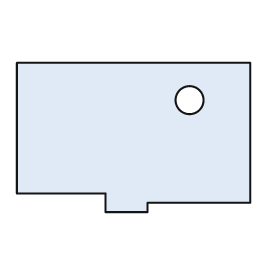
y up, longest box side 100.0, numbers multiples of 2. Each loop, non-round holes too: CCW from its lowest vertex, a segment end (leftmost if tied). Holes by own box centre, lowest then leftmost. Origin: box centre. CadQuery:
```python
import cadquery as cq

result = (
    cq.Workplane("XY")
    .moveTo(-12.0, -32.0)
    .lineTo(6.0, -32.0)
    .lineTo(6.0, -28.0)
    .lineTo(50.0, -28.0)
    .lineTo(50.0, 32.0)
    .lineTo(-50.0, 32.0)
    .lineTo(-50.0, -24.0)
    .lineTo(-12.0, -24.0)
    .close()
    .moveTo(24.0, 16.0)
    .circle(6.0)
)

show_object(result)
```